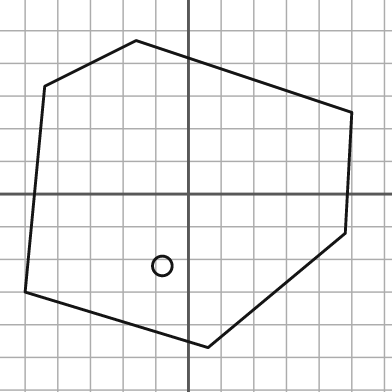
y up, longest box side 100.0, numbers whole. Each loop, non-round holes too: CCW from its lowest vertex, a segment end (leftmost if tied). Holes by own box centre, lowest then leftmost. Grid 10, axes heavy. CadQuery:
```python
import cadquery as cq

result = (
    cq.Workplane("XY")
    .moveTo(6.0, -47.0)
    .lineTo(48.0, -12.0)
    .lineTo(50.0, 25.0)
    .lineTo(-16.0, 47.0)
    .lineTo(-44.0, 33.0)
    .lineTo(-50.0, -30.0)
    .close()
    .moveTo(-8.0, -22.0)
    .circle(3.0)
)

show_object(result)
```